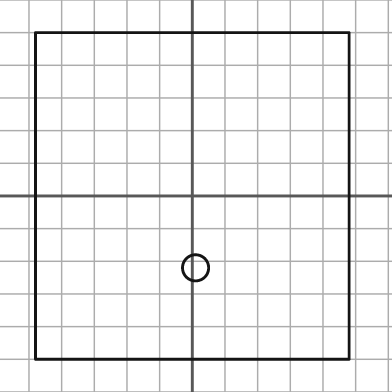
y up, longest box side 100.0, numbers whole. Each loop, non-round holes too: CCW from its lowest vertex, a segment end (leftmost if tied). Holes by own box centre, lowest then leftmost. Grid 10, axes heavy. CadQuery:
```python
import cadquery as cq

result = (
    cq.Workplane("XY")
    .moveTo(-48.0, -50.0)
    .lineTo(48.0, -50.0)
    .lineTo(48.0, 50.0)
    .lineTo(-48.0, 50.0)
    .close()
    .moveTo(1.0, -22.0)
    .circle(4.0)
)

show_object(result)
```